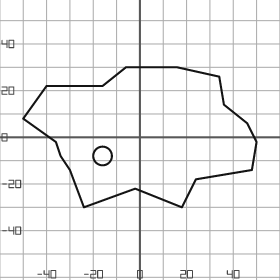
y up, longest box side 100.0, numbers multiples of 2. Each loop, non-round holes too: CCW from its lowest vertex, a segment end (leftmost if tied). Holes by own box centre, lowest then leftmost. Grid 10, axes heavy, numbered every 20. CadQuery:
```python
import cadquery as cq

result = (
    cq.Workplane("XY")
    .moveTo(-24.0, -30.0)
    .lineTo(-2.0, -22.0)
    .lineTo(18.0, -30.0)
    .lineTo(24.0, -18.0)
    .lineTo(48.0, -14.0)
    .lineTo(50.0, -2.0)
    .lineTo(46.0, 6.0)
    .lineTo(36.0, 14.0)
    .lineTo(34.0, 26.0)
    .lineTo(16.0, 30.0)
    .lineTo(-6.0, 30.0)
    .lineTo(-16.0, 22.0)
    .lineTo(-40.0, 22.0)
    .lineTo(-50.0, 8.0)
    .lineTo(-36.0, -2.0)
    .lineTo(-34.0, -8.0)
    .lineTo(-30.0, -14.0)
    .close()
    .moveTo(-16.0, -8.0)
    .circle(4.0)
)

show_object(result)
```